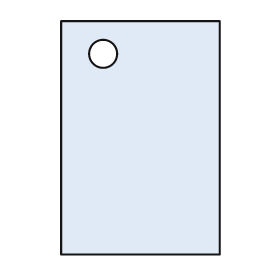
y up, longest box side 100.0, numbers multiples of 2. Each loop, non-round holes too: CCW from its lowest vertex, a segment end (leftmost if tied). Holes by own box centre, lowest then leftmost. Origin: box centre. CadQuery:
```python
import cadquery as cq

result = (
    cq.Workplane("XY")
    .moveTo(-34.0, -50.0)
    .lineTo(34.0, -50.0)
    .lineTo(34.0, 50.0)
    .lineTo(-34.0, 50.0)
    .close()
    .moveTo(-16.0, 36.0)
    .circle(6.0)
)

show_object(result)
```